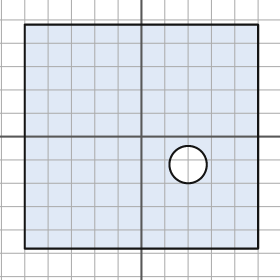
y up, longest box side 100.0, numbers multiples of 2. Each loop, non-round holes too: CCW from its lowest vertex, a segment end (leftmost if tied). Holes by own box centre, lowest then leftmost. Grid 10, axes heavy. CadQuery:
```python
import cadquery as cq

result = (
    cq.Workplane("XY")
    .moveTo(-50.0, -48.0)
    .lineTo(50.0, -48.0)
    .lineTo(50.0, 48.0)
    .lineTo(-50.0, 48.0)
    .close()
    .moveTo(20.0, -12.0)
    .circle(8.0)
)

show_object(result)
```